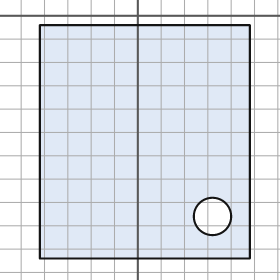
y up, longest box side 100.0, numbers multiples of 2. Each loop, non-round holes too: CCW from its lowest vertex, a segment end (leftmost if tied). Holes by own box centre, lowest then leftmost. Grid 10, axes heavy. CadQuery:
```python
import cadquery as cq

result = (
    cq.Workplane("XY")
    .moveTo(-42.0, -104.0)
    .lineTo(48.0, -104.0)
    .lineTo(48.0, -4.0)
    .lineTo(-42.0, -4.0)
    .close()
    .moveTo(32.0, -86.0)
    .circle(8.0)
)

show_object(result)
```